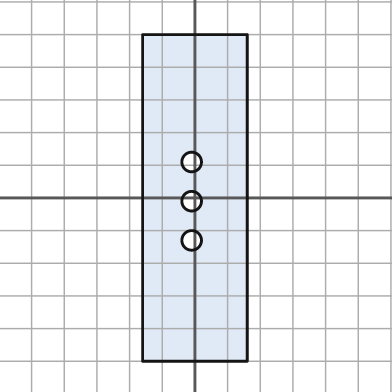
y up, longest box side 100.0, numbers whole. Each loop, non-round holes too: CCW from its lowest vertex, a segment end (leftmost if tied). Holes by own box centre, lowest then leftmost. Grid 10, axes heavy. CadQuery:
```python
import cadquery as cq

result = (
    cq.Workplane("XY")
    .moveTo(-16.0, -50.0)
    .lineTo(16.0, -50.0)
    .lineTo(16.0, 50.0)
    .lineTo(-16.0, 50.0)
    .close()
    .moveTo(-1.0, -13.0)
    .circle(3.0)
    .moveTo(-1.0, -1.0)
    .circle(3.0)
    .moveTo(-1.0, 11.0)
    .circle(3.0)
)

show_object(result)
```